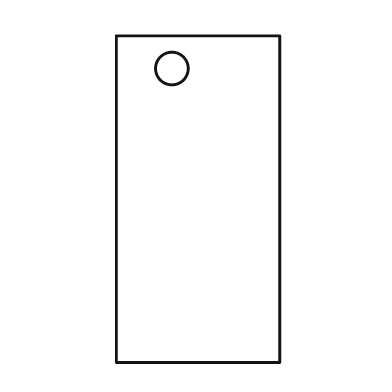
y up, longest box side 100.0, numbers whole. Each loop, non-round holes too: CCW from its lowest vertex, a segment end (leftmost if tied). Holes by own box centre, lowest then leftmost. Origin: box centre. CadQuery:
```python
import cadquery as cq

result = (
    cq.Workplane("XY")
    .moveTo(-25.0, -50.0)
    .lineTo(25.0, -50.0)
    .lineTo(25.0, 50.0)
    .lineTo(-25.0, 50.0)
    .close()
    .moveTo(-8.0, 40.0)
    .circle(5.0)
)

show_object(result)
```